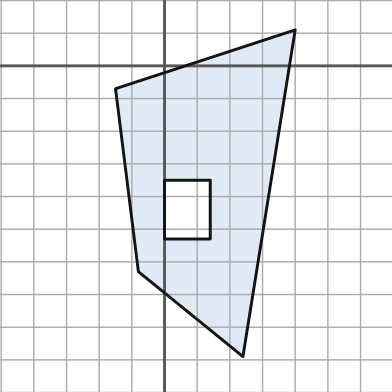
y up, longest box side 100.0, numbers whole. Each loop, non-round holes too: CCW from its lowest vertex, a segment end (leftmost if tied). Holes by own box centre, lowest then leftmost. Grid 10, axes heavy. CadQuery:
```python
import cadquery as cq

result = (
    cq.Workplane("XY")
    .moveTo(24.0, -89.0)
    .lineTo(40.0, 11.0)
    .lineTo(-15.0, -7.0)
    .lineTo(-8.0, -63.0)
    .close()
    .moveTo(0.0, -53.0)
    .lineTo(14.0, -53.0)
    .lineTo(14.0, -35.0)
    .lineTo(0.0, -35.0)
    .close()
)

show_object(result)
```